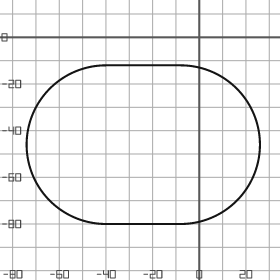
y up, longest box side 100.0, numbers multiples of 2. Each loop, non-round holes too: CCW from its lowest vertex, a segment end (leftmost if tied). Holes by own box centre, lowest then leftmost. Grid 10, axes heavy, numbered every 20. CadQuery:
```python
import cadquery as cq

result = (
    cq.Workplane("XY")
    .moveTo(-40.0, -80.0)
    .lineTo(-8.0, -80.0)
    .threePointArc((26.0, -46.0), (-8.0, -12.0))
    .lineTo(-40.0, -12.0)
    .threePointArc((-74.0, -46.0), (-40.0, -80.0))
    .close()
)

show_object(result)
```